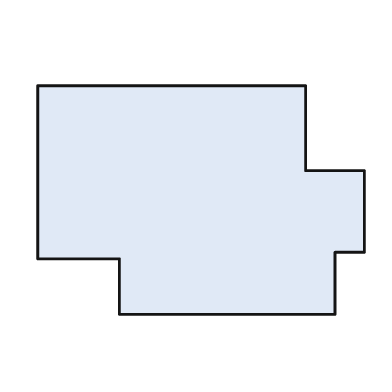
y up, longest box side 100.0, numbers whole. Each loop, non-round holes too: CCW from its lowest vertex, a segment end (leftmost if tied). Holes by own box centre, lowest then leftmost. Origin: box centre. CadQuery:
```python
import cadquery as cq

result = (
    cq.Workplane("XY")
    .moveTo(-25.0, -35.0)
    .lineTo(41.0, -35.0)
    .lineTo(41.0, -16.0)
    .lineTo(50.0, -16.0)
    .lineTo(50.0, 9.0)
    .lineTo(32.0, 9.0)
    .lineTo(32.0, 35.0)
    .lineTo(-50.0, 35.0)
    .lineTo(-50.0, -18.0)
    .lineTo(-25.0, -18.0)
    .close()
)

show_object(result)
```